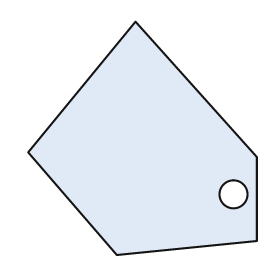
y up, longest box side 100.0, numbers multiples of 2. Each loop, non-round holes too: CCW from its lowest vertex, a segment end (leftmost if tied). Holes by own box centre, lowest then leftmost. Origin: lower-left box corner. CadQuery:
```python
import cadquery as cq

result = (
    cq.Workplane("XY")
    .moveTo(38.0, 0.0)
    .lineTo(98.0, 6.0)
    .lineTo(98.0, 42.0)
    .lineTo(46.0, 100.0)
    .lineTo(0.0, 44.0)
    .close()
    .moveTo(88.0, 26.0)
    .circle(6.0)
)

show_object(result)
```